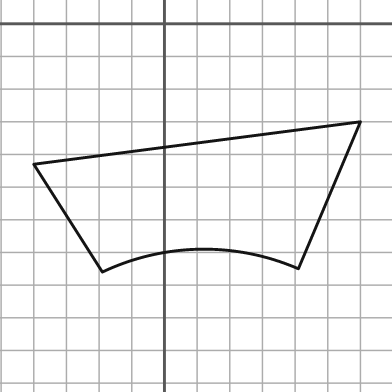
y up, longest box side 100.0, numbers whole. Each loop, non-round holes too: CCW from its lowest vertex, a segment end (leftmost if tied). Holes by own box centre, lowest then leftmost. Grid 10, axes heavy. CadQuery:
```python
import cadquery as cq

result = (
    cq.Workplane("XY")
    .moveTo(-19.0, -76.0)
    .threePointArc((11.0, -69.0), (41.0, -75.0))
    .lineTo(60.0, -30.0)
    .lineTo(-40.0, -43.0)
    .close()
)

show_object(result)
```